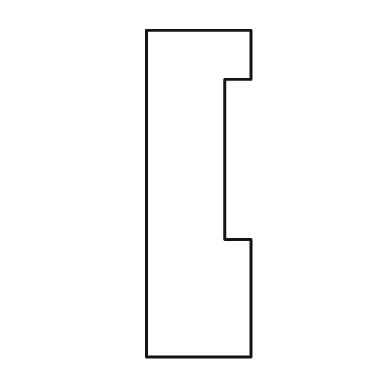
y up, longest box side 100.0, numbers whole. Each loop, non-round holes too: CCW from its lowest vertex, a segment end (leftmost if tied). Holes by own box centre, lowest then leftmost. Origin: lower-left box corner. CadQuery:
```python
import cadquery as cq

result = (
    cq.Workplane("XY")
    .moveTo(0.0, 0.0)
    .lineTo(32.0, 0.0)
    .lineTo(32.0, 36.0)
    .lineTo(24.0, 36.0)
    .lineTo(24.0, 85.0)
    .lineTo(32.0, 85.0)
    .lineTo(32.0, 100.0)
    .lineTo(0.0, 100.0)
    .close()
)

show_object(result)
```